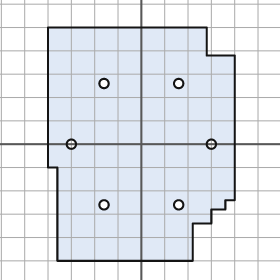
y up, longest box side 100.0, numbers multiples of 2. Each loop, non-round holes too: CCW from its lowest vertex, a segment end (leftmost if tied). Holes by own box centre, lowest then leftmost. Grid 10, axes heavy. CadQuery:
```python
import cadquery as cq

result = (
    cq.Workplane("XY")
    .moveTo(-36.0, -50.0)
    .lineTo(22.0, -50.0)
    .lineTo(22.0, -34.0)
    .lineTo(30.0, -34.0)
    .lineTo(30.0, -28.0)
    .lineTo(36.0, -28.0)
    .lineTo(36.0, -24.0)
    .lineTo(40.0, -24.0)
    .lineTo(40.0, 38.0)
    .lineTo(28.0, 38.0)
    .lineTo(28.0, 50.0)
    .lineTo(-40.0, 50.0)
    .lineTo(-40.0, -10.0)
    .lineTo(-36.0, -10.0)
    .close()
    .moveTo(-16.0, -26.0)
    .circle(2.0)
    .moveTo(16.0, -26.0)
    .circle(2.0)
    .moveTo(-30.0, 0.0)
    .circle(2.0)
    .moveTo(30.0, 0.0)
    .circle(2.0)
    .moveTo(-16.0, 26.0)
    .circle(2.0)
    .moveTo(16.0, 26.0)
    .circle(2.0)
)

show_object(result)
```